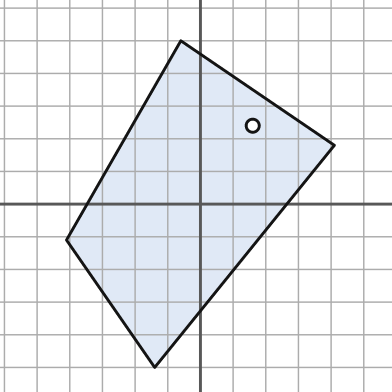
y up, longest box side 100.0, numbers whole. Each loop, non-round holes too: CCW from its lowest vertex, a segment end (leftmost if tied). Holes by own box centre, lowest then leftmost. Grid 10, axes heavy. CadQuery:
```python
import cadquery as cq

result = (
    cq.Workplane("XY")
    .moveTo(-14.0, -50.0)
    .lineTo(41.0, 18.0)
    .lineTo(-6.0, 50.0)
    .lineTo(-41.0, -11.0)
    .close()
    .moveTo(16.0, 24.0)
    .circle(2.0)
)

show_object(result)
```